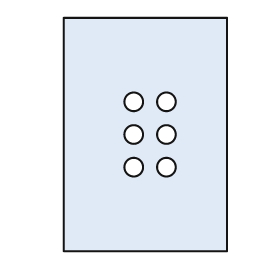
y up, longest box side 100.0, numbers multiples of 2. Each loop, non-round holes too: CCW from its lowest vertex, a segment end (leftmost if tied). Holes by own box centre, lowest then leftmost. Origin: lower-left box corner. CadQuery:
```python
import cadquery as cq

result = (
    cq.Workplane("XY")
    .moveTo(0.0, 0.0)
    .lineTo(70.0, 0.0)
    .lineTo(70.0, 100.0)
    .lineTo(0.0, 100.0)
    .close()
    .moveTo(30.0, 36.0)
    .circle(4.0)
    .moveTo(44.0, 36.0)
    .circle(4.0)
    .moveTo(30.0, 50.0)
    .circle(4.0)
    .moveTo(44.0, 50.0)
    .circle(4.0)
    .moveTo(30.0, 64.0)
    .circle(4.0)
    .moveTo(44.0, 64.0)
    .circle(4.0)
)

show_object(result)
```